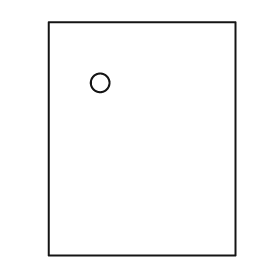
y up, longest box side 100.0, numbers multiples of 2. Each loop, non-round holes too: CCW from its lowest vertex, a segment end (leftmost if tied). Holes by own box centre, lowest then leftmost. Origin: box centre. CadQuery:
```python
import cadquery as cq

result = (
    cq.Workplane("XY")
    .moveTo(-40.0, -50.0)
    .lineTo(40.0, -50.0)
    .lineTo(40.0, 50.0)
    .lineTo(-40.0, 50.0)
    .close()
    .moveTo(-18.0, 24.0)
    .circle(4.0)
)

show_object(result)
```